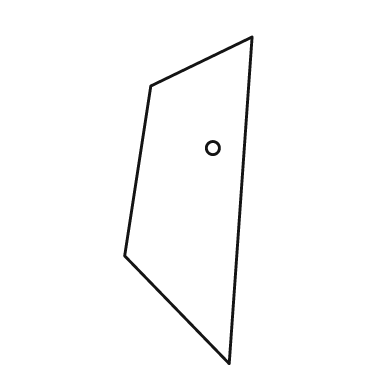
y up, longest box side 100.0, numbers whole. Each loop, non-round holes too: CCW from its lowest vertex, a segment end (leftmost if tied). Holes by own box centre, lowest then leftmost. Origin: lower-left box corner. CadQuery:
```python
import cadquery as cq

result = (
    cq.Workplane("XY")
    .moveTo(32.0, 0.0)
    .lineTo(39.0, 100.0)
    .lineTo(8.0, 85.0)
    .lineTo(0.0, 33.0)
    .close()
    .moveTo(27.0, 66.0)
    .circle(2.0)
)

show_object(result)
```